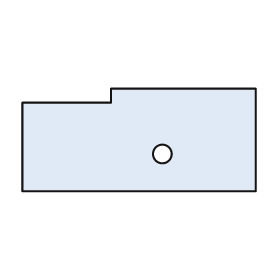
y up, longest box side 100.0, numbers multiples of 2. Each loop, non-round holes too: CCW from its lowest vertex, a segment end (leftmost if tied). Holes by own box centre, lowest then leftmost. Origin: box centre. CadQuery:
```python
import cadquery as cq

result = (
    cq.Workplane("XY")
    .moveTo(-50.0, -22.0)
    .lineTo(50.0, -22.0)
    .lineTo(50.0, 22.0)
    .lineTo(-12.0, 22.0)
    .lineTo(-12.0, 16.0)
    .lineTo(-50.0, 16.0)
    .close()
    .moveTo(10.0, -6.0)
    .circle(4.0)
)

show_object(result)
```